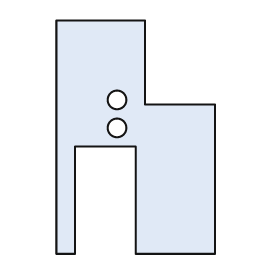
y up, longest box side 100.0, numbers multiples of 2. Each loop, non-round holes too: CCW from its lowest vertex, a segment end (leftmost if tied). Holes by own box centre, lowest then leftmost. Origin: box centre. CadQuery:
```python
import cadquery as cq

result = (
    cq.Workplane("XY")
    .moveTo(-34.0, -50.0)
    .lineTo(-26.0, -50.0)
    .lineTo(-26.0, -4.0)
    .lineTo(0.0, -4.0)
    .lineTo(0.0, -50.0)
    .lineTo(34.0, -50.0)
    .lineTo(34.0, 14.0)
    .lineTo(4.0, 14.0)
    .lineTo(4.0, 50.0)
    .lineTo(-34.0, 50.0)
    .close()
    .moveTo(-8.0, 4.0)
    .circle(4.0)
    .moveTo(-8.0, 16.0)
    .circle(4.0)
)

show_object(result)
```